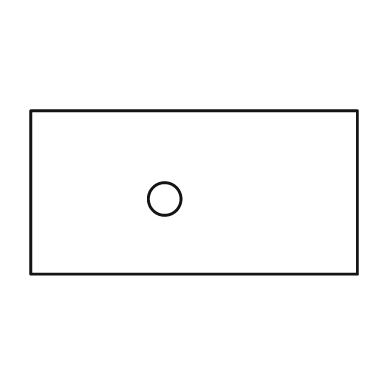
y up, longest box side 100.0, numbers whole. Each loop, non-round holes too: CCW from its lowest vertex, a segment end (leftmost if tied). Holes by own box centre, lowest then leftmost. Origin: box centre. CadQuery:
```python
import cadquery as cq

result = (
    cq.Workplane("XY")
    .moveTo(-50.0, -25.0)
    .lineTo(50.0, -25.0)
    .lineTo(50.0, 25.0)
    .lineTo(-50.0, 25.0)
    .close()
    .moveTo(-9.0, -2.0)
    .circle(5.0)
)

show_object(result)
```